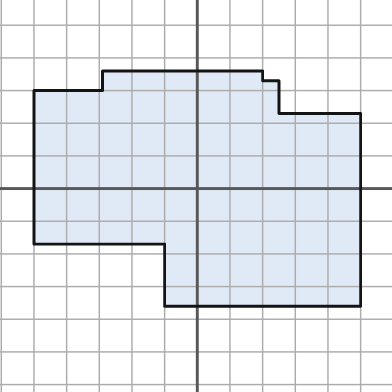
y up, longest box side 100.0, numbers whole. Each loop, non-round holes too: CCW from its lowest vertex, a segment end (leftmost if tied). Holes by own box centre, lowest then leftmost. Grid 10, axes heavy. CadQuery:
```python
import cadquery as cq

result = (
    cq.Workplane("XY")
    .moveTo(-10.0, -36.0)
    .lineTo(50.0, -36.0)
    .lineTo(50.0, 23.0)
    .lineTo(25.0, 23.0)
    .lineTo(25.0, 33.0)
    .lineTo(20.0, 33.0)
    .lineTo(20.0, 36.0)
    .lineTo(-29.0, 36.0)
    .lineTo(-29.0, 30.0)
    .lineTo(-50.0, 30.0)
    .lineTo(-50.0, -17.0)
    .lineTo(-10.0, -17.0)
    .close()
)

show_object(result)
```